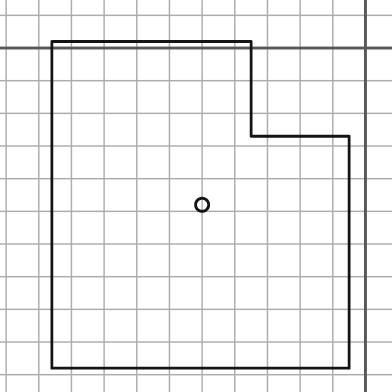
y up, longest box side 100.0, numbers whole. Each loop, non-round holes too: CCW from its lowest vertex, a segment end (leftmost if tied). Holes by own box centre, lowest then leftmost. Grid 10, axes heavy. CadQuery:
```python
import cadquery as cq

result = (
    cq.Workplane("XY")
    .moveTo(-96.0, -98.0)
    .lineTo(-5.0, -98.0)
    .lineTo(-5.0, -27.0)
    .lineTo(-35.0, -27.0)
    .lineTo(-35.0, 2.0)
    .lineTo(-96.0, 2.0)
    .close()
    .moveTo(-50.0, -48.0)
    .circle(2.0)
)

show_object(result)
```